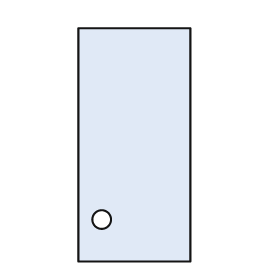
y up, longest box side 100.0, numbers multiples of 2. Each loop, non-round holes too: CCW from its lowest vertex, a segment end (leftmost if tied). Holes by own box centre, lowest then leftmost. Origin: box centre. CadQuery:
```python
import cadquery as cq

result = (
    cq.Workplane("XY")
    .moveTo(-24.0, -50.0)
    .lineTo(24.0, -50.0)
    .lineTo(24.0, 50.0)
    .lineTo(-24.0, 50.0)
    .close()
    .moveTo(-14.0, -32.0)
    .circle(4.0)
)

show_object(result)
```